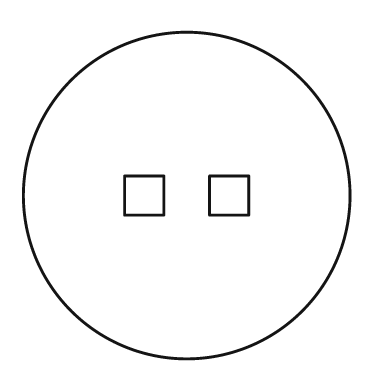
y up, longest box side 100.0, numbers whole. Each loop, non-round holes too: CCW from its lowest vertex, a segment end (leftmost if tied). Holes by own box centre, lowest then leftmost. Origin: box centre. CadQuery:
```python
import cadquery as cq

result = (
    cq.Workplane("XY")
    .moveTo(0.0, 0.0)
    .circle(50.0)
    .moveTo(-19.0, -6.0)
    .lineTo(-7.0, -6.0)
    .lineTo(-7.0, 6.0)
    .lineTo(-19.0, 6.0)
    .close()
    .moveTo(7.0, -6.0)
    .lineTo(19.0, -6.0)
    .lineTo(19.0, 6.0)
    .lineTo(7.0, 6.0)
    .close()
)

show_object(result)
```